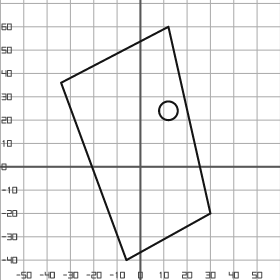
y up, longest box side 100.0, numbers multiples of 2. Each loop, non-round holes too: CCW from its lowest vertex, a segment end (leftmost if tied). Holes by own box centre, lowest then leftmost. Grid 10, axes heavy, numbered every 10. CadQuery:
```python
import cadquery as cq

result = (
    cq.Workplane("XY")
    .moveTo(-6.0, -40.0)
    .lineTo(30.0, -20.0)
    .lineTo(12.0, 60.0)
    .lineTo(-34.0, 36.0)
    .close()
    .moveTo(12.0, 24.0)
    .circle(4.0)
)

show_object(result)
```